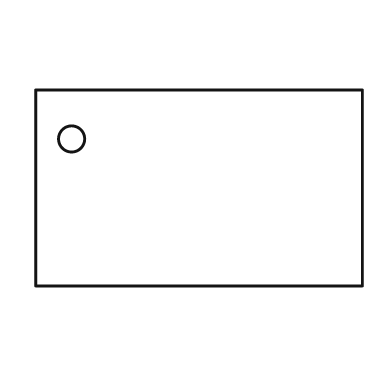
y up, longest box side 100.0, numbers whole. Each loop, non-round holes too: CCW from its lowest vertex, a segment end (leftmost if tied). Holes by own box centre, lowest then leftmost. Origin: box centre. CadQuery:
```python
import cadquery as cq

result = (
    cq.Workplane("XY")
    .moveTo(-50.0, -30.0)
    .lineTo(50.0, -30.0)
    .lineTo(50.0, 30.0)
    .lineTo(-50.0, 30.0)
    .close()
    .moveTo(-39.0, 15.0)
    .circle(4.0)
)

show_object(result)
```